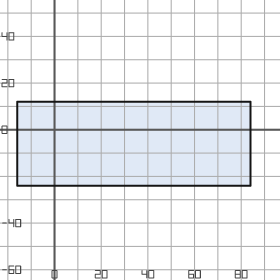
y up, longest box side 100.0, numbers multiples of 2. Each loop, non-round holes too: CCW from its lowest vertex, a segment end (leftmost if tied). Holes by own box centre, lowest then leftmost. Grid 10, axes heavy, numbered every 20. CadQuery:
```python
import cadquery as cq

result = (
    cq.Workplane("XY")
    .moveTo(-16.0, -24.0)
    .lineTo(84.0, -24.0)
    .lineTo(84.0, 12.0)
    .lineTo(-16.0, 12.0)
    .close()
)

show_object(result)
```